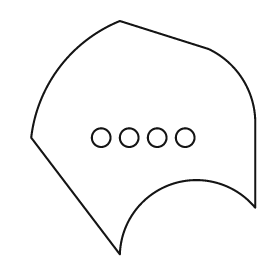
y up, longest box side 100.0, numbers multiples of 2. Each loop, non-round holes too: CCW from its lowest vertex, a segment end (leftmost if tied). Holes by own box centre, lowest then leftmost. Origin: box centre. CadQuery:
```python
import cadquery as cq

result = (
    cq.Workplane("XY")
    .moveTo(-10.0, -50.0)
    .threePointArc((12.0, -20.0), (48.0, -30.0))
    .lineTo(48.0, 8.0)
    .threePointArc((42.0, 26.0), (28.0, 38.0))
    .lineTo(-10.0, 50.0)
    .threePointArc((-36.0, 30.0), (-48.0, 0.0))
    .close()
    .moveTo(-18.0, 0.0)
    .circle(4.0)
    .moveTo(-6.0, 0.0)
    .circle(4.0)
    .moveTo(6.0, 0.0)
    .circle(4.0)
    .moveTo(18.0, 0.0)
    .circle(4.0)
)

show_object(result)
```